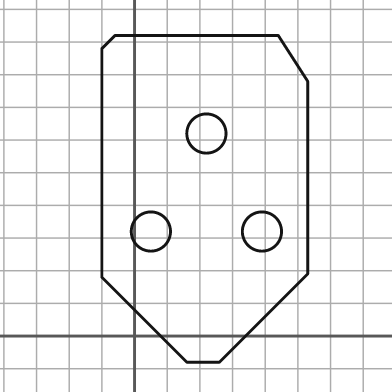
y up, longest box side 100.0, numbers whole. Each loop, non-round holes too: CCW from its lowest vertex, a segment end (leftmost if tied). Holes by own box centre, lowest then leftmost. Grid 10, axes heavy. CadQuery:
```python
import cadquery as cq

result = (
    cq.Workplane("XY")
    .moveTo(16.0, -8.0)
    .lineTo(26.0, -8.0)
    .lineTo(53.0, 19.0)
    .lineTo(53.0, 78.0)
    .lineTo(44.0, 92.0)
    .lineTo(-6.0, 92.0)
    .lineTo(-10.0, 88.0)
    .lineTo(-10.0, 18.0)
    .close()
    .moveTo(5.0, 32.0)
    .circle(6.0)
    .moveTo(39.0, 32.0)
    .circle(6.0)
    .moveTo(22.0, 62.0)
    .circle(6.0)
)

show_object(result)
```